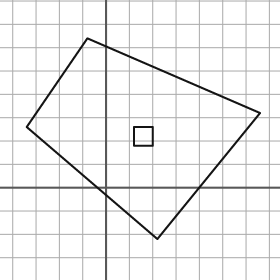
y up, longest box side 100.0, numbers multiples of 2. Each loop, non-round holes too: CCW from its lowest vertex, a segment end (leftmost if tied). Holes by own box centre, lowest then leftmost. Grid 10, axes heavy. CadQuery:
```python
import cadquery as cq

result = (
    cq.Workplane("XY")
    .moveTo(22.0, -22.0)
    .lineTo(66.0, 32.0)
    .lineTo(-8.0, 64.0)
    .lineTo(-34.0, 26.0)
    .close()
    .moveTo(12.0, 18.0)
    .lineTo(20.0, 18.0)
    .lineTo(20.0, 26.0)
    .lineTo(12.0, 26.0)
    .close()
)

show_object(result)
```